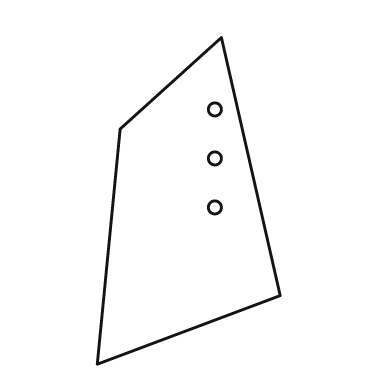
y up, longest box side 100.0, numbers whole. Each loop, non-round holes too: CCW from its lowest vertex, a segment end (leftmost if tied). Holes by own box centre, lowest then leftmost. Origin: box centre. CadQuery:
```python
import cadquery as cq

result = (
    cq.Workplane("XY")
    .moveTo(-28.0, -50.0)
    .lineTo(28.0, -29.0)
    .lineTo(10.0, 50.0)
    .lineTo(-21.0, 22.0)
    .close()
    .moveTo(8.0, -2.0)
    .circle(2.0)
    .moveTo(8.0, 13.0)
    .circle(2.0)
    .moveTo(8.0, 28.0)
    .circle(2.0)
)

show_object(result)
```